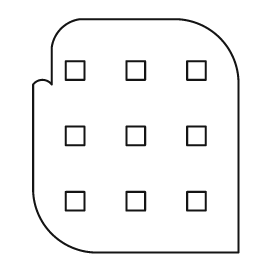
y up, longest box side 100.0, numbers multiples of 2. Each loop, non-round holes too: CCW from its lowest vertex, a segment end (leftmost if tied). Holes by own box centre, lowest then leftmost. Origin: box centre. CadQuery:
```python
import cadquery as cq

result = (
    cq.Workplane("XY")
    .moveTo(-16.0, -50.0)
    .lineTo(44.0, -50.0)
    .lineTo(44.0, 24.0)
    .threePointArc((36.0, 42.0), (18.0, 50.0))
    .lineTo(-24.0, 50.0)
    .threePointArc((-32.0, 46.0), (-36.0, 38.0))
    .lineTo(-36.0, 22.0)
    .threePointArc((-40.0, 24.0), (-44.0, 22.0))
    .lineTo(-44.0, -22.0)
    .threePointArc((-36.0, -42.0), (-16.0, -50.0))
    .close()
    .moveTo(-30.0, -32.0)
    .lineTo(-22.0, -32.0)
    .lineTo(-22.0, -24.0)
    .lineTo(-30.0, -24.0)
    .close()
    .moveTo(-4.0, -32.0)
    .lineTo(4.0, -32.0)
    .lineTo(4.0, -24.0)
    .lineTo(-4.0, -24.0)
    .close()
    .moveTo(22.0, -32.0)
    .lineTo(30.0, -32.0)
    .lineTo(30.0, -24.0)
    .lineTo(22.0, -24.0)
    .close()
    .moveTo(-30.0, -4.0)
    .lineTo(-22.0, -4.0)
    .lineTo(-22.0, 4.0)
    .lineTo(-30.0, 4.0)
    .close()
    .moveTo(-4.0, -4.0)
    .lineTo(4.0, -4.0)
    .lineTo(4.0, 4.0)
    .lineTo(-4.0, 4.0)
    .close()
    .moveTo(22.0, -4.0)
    .lineTo(30.0, -4.0)
    .lineTo(30.0, 4.0)
    .lineTo(22.0, 4.0)
    .close()
    .moveTo(-30.0, 24.0)
    .lineTo(-22.0, 24.0)
    .lineTo(-22.0, 32.0)
    .lineTo(-30.0, 32.0)
    .close()
    .moveTo(-4.0, 24.0)
    .lineTo(4.0, 24.0)
    .lineTo(4.0, 32.0)
    .lineTo(-4.0, 32.0)
    .close()
    .moveTo(22.0, 24.0)
    .lineTo(30.0, 24.0)
    .lineTo(30.0, 32.0)
    .lineTo(22.0, 32.0)
    .close()
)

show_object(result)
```